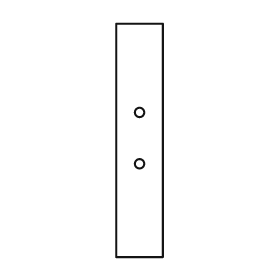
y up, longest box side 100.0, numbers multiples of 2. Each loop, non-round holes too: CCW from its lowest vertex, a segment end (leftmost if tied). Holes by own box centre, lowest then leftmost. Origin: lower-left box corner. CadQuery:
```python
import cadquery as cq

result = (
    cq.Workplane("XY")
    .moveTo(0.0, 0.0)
    .lineTo(20.0, 0.0)
    .lineTo(20.0, 100.0)
    .lineTo(0.0, 100.0)
    .close()
    .moveTo(10.0, 40.0)
    .circle(2.0)
    .moveTo(10.0, 62.0)
    .circle(2.0)
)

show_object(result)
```